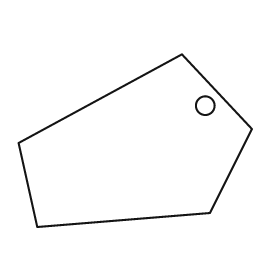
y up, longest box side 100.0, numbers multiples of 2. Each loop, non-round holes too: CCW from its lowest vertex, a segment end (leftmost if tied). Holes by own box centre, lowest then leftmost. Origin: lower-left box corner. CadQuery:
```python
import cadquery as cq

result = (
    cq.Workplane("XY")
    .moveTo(8.0, 0.0)
    .lineTo(82.0, 6.0)
    .lineTo(100.0, 42.0)
    .lineTo(70.0, 74.0)
    .lineTo(0.0, 36.0)
    .close()
    .moveTo(80.0, 52.0)
    .circle(4.0)
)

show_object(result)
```